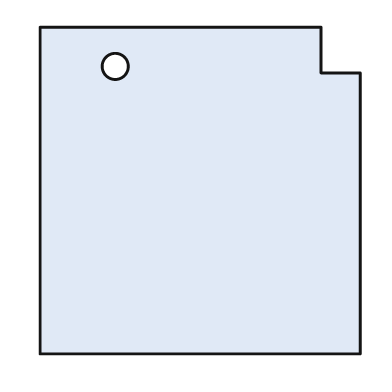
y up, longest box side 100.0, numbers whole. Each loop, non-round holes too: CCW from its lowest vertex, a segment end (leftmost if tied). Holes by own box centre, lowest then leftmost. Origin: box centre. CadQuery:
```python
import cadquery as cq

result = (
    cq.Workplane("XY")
    .moveTo(-49.0, -50.0)
    .lineTo(49.0, -50.0)
    .lineTo(49.0, 36.0)
    .lineTo(37.0, 36.0)
    .lineTo(37.0, 50.0)
    .lineTo(-49.0, 50.0)
    .close()
    .moveTo(-26.0, 38.0)
    .circle(4.0)
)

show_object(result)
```